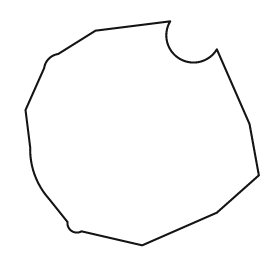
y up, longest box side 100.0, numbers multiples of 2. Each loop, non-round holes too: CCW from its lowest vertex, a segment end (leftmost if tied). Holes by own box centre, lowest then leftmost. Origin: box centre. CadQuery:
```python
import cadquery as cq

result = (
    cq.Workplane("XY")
    .moveTo(0.0, -48.0)
    .lineTo(32.0, -34.0)
    .lineTo(50.0, -18.0)
    .lineTo(46.0, 4.0)
    .lineTo(32.0, 36.0)
    .threePointArc((16.0, 32.0), (12.0, 48.0))
    .lineTo(-20.0, 44.0)
    .lineTo(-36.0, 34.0)
    .threePointArc((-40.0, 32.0), (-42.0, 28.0))
    .lineTo(-50.0, 10.0)
    .lineTo(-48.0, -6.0)
    .threePointArc((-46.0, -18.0), (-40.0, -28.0))
    .lineTo(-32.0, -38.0)
    .threePointArc((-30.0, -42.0), (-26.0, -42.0))
    .close()
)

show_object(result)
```